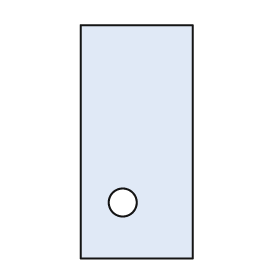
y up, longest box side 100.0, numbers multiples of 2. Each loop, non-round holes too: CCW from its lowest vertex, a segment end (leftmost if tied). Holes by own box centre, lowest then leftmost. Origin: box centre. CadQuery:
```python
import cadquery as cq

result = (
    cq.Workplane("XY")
    .moveTo(-24.0, -50.0)
    .lineTo(24.0, -50.0)
    .lineTo(24.0, 50.0)
    .lineTo(-24.0, 50.0)
    .close()
    .moveTo(-6.0, -26.0)
    .circle(6.0)
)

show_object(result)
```